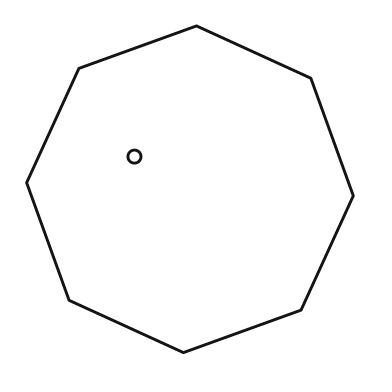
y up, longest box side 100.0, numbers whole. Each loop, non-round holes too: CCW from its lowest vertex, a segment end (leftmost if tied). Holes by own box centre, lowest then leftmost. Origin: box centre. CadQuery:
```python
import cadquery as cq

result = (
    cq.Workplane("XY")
    .moveTo(-2.0, -50.0)
    .lineTo(34.0, -37.0)
    .lineTo(50.0, -2.0)
    .lineTo(37.0, 34.0)
    .lineTo(2.0, 50.0)
    .lineTo(-34.0, 37.0)
    .lineTo(-50.0, 2.0)
    .lineTo(-37.0, -34.0)
    .close()
    .moveTo(-17.0, 10.0)
    .circle(2.0)
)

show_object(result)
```